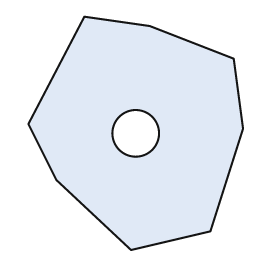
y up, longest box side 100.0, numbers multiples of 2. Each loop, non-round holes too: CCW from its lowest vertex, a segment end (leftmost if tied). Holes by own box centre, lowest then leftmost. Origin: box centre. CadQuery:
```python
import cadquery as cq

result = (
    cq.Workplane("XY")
    .moveTo(-2.0, -50.0)
    .lineTo(32.0, -42.0)
    .lineTo(46.0, 2.0)
    .lineTo(42.0, 32.0)
    .lineTo(6.0, 46.0)
    .lineTo(-22.0, 50.0)
    .lineTo(-46.0, 4.0)
    .lineTo(-34.0, -20.0)
    .close()
    .moveTo(0.0, 0.0)
    .circle(10.0)
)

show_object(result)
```